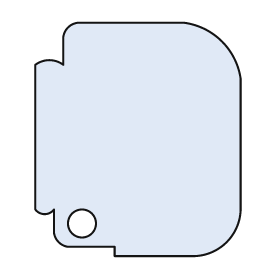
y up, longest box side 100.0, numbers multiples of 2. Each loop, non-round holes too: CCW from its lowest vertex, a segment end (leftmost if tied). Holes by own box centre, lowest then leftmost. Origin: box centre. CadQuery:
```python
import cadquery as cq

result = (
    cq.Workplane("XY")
    .moveTo(-10.0, -50.0)
    .lineTo(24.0, -50.0)
    .threePointArc((38.0, -44.0), (44.0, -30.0))
    .lineTo(44.0, 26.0)
    .threePointArc((36.0, 42.0), (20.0, 50.0))
    .lineTo(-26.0, 50.0)
    .threePointArc((-30.0, 48.0), (-32.0, 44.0))
    .lineTo(-32.0, 32.0)
    .threePointArc((-38.0, 34.0), (-44.0, 32.0))
    .lineTo(-44.0, -30.0)
    .threePointArc((-40.0, -32.0), (-36.0, -30.0))
    .lineTo(-36.0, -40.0)
    .threePointArc((-34.0, -44.0), (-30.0, -46.0))
    .lineTo(-10.0, -46.0)
    .close()
    .moveTo(-24.0, -36.0)
    .circle(6.0)
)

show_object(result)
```